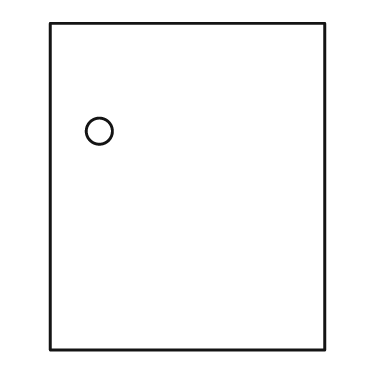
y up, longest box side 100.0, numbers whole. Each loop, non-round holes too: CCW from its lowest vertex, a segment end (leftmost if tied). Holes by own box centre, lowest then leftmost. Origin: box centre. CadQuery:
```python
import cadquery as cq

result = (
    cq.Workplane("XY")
    .moveTo(-42.0, -50.0)
    .lineTo(42.0, -50.0)
    .lineTo(42.0, 50.0)
    .lineTo(-42.0, 50.0)
    .close()
    .moveTo(-27.0, 17.0)
    .circle(4.0)
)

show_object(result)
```